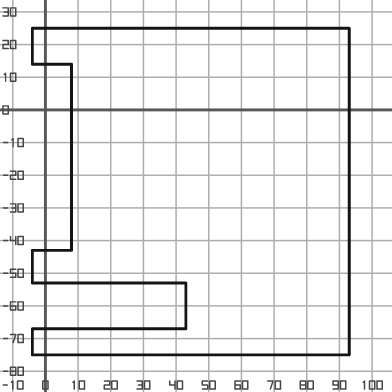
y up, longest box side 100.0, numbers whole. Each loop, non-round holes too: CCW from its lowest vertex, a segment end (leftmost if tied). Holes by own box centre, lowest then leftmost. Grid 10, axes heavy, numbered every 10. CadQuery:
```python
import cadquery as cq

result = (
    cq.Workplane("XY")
    .moveTo(-4.0, -75.0)
    .lineTo(93.0, -75.0)
    .lineTo(93.0, 25.0)
    .lineTo(-4.0, 25.0)
    .lineTo(-4.0, 14.0)
    .lineTo(8.0, 14.0)
    .lineTo(8.0, -43.0)
    .lineTo(-4.0, -43.0)
    .lineTo(-4.0, -53.0)
    .lineTo(43.0, -53.0)
    .lineTo(43.0, -67.0)
    .lineTo(-4.0, -67.0)
    .close()
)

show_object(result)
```